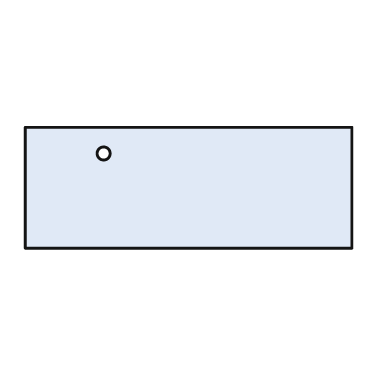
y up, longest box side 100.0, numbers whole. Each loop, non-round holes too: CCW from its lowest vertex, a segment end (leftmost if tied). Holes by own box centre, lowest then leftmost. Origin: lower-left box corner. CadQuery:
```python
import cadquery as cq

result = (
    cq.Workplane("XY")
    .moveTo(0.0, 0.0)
    .lineTo(100.0, 0.0)
    .lineTo(100.0, 37.0)
    .lineTo(0.0, 37.0)
    .close()
    .moveTo(24.0, 29.0)
    .circle(2.0)
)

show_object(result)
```